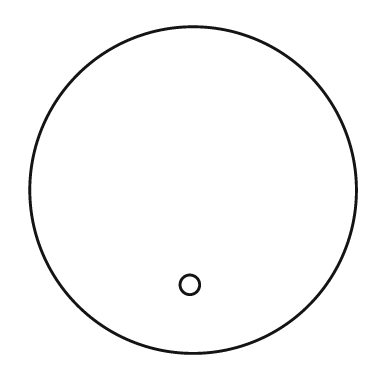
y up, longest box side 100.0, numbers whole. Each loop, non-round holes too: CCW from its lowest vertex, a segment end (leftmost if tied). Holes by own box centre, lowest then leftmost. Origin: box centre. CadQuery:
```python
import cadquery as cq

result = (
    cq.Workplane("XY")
    .moveTo(0.0, 0.0)
    .circle(50.0)
    .moveTo(-1.0, -29.0)
    .circle(3.0)
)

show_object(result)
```